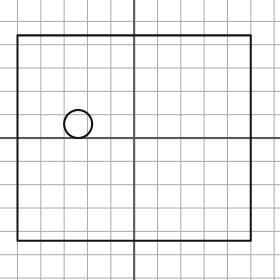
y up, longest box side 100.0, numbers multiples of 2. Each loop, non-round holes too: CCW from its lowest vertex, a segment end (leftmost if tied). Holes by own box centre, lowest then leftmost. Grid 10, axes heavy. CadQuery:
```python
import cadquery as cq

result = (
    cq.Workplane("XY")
    .moveTo(-50.0, -44.0)
    .lineTo(50.0, -44.0)
    .lineTo(50.0, 44.0)
    .lineTo(-50.0, 44.0)
    .close()
    .moveTo(-24.0, 6.0)
    .circle(6.0)
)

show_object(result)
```